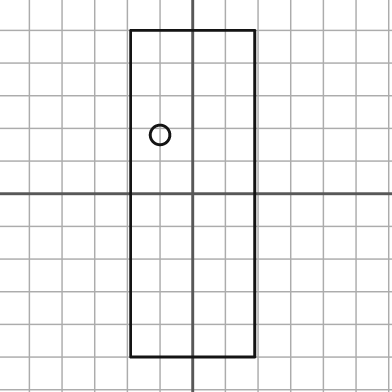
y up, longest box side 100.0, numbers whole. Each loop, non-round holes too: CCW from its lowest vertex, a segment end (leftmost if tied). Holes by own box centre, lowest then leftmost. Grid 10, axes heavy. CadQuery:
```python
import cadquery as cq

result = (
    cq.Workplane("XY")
    .moveTo(-19.0, -50.0)
    .lineTo(19.0, -50.0)
    .lineTo(19.0, 50.0)
    .lineTo(-19.0, 50.0)
    .close()
    .moveTo(-10.0, 18.0)
    .circle(3.0)
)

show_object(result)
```